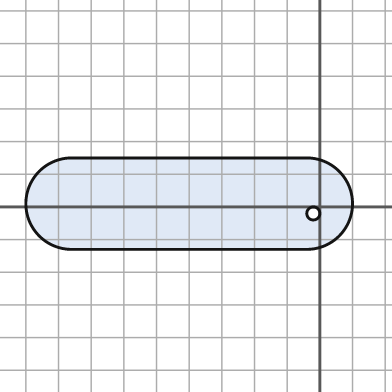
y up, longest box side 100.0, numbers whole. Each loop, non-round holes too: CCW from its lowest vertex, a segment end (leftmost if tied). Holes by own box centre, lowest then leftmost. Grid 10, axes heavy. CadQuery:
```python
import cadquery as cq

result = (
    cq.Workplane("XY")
    .moveTo(-76.0, -13.0)
    .lineTo(-4.0, -13.0)
    .threePointArc((10.0, 1.0), (-4.0, 15.0))
    .lineTo(-76.0, 15.0)
    .threePointArc((-90.0, 1.0), (-76.0, -13.0))
    .close()
    .moveTo(-2.0, -2.0)
    .circle(2.0)
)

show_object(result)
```